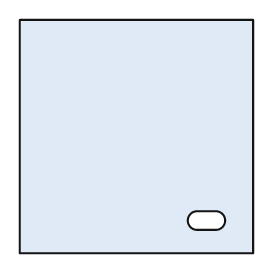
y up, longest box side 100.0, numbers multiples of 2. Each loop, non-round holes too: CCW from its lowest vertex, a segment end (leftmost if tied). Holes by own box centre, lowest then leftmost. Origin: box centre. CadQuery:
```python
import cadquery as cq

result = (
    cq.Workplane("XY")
    .moveTo(-50.0, -50.0)
    .lineTo(50.0, -50.0)
    .lineTo(50.0, 50.0)
    .lineTo(-50.0, 50.0)
    .close()
    .moveTo(26.0, -40.0)
    .lineTo(34.0, -40.0)
    .threePointArc((38.0, -36.0), (34.0, -32.0))
    .lineTo(26.0, -32.0)
    .threePointArc((22.0, -36.0), (26.0, -40.0))
    .close()
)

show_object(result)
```